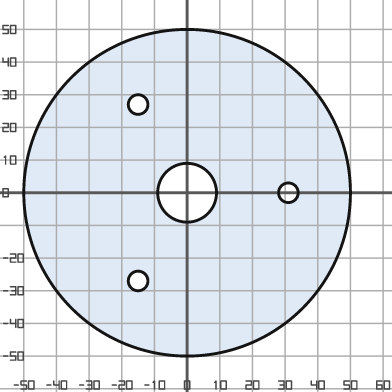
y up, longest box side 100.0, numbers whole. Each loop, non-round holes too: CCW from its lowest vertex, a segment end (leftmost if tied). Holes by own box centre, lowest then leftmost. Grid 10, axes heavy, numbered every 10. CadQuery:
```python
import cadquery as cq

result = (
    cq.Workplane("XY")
    .moveTo(0.0, 0.0)
    .circle(50.0)
    .moveTo(-15.0, -27.0)
    .circle(3.0)
    .moveTo(0.0, 0.0)
    .circle(9.0)
    .moveTo(31.0, 0.0)
    .circle(3.0)
    .moveTo(-15.0, 27.0)
    .circle(3.0)
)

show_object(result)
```